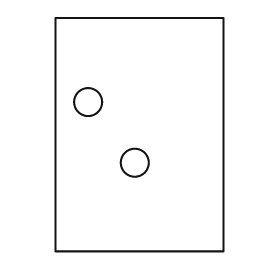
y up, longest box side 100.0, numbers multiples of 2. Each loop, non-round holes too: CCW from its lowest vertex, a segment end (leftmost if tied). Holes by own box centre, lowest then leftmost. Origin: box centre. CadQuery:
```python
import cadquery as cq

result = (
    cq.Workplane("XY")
    .moveTo(-36.0, -50.0)
    .lineTo(36.0, -50.0)
    .lineTo(36.0, 50.0)
    .lineTo(-36.0, 50.0)
    .close()
    .moveTo(-2.0, -12.0)
    .circle(6.0)
    .moveTo(-22.0, 14.0)
    .circle(6.0)
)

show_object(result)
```